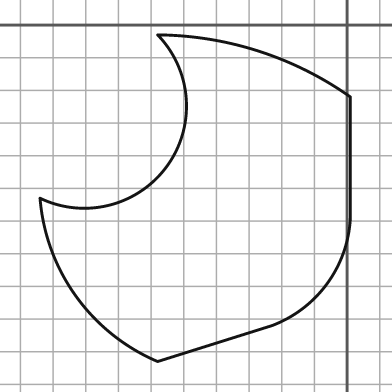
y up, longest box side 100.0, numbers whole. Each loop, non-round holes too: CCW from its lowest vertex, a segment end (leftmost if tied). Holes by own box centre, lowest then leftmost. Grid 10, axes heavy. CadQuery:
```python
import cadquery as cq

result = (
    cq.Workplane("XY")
    .moveTo(-58.0, -103.0)
    .lineTo(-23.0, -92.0)
    .threePointArc((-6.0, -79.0), (1.0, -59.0))
    .lineTo(1.0, -22.0)
    .threePointArc((-27.0, -8.0), (-58.0, -3.0))
    .threePointArc((-55.0, -43.0), (-94.0, -53.0))
    .threePointArc((-83.0, -83.0), (-58.0, -103.0))
    .close()
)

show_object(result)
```